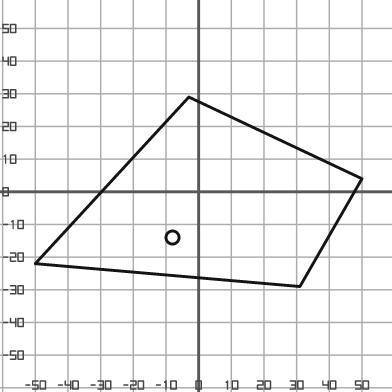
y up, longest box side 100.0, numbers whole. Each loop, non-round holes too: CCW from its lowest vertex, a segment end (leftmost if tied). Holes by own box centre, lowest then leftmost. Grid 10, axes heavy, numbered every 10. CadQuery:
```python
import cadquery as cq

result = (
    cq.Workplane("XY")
    .moveTo(31.0, -29.0)
    .lineTo(50.0, 4.0)
    .lineTo(-3.0, 29.0)
    .lineTo(-50.0, -22.0)
    .close()
    .moveTo(-8.0, -14.0)
    .circle(2.0)
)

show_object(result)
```